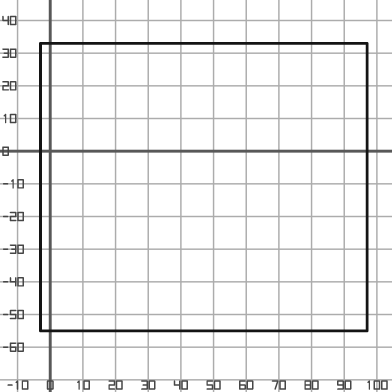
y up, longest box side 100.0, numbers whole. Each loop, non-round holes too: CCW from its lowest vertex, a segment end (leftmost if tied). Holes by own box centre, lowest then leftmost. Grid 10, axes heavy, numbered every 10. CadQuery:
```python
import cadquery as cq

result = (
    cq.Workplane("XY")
    .moveTo(-3.0, -55.0)
    .lineTo(97.0, -55.0)
    .lineTo(97.0, 33.0)
    .lineTo(-3.0, 33.0)
    .close()
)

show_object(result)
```